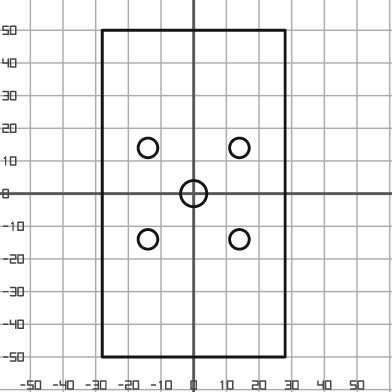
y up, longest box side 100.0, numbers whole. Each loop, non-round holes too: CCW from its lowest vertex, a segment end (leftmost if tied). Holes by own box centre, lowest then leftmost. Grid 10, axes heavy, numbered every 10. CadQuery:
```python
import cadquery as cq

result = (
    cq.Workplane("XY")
    .moveTo(-28.0, -50.0)
    .lineTo(28.0, -50.0)
    .lineTo(28.0, 50.0)
    .lineTo(-28.0, 50.0)
    .close()
    .moveTo(-14.0, -14.0)
    .circle(3.0)
    .moveTo(14.0, -14.0)
    .circle(3.0)
    .moveTo(0.0, 0.0)
    .circle(4.0)
    .moveTo(-14.0, 14.0)
    .circle(3.0)
    .moveTo(14.0, 14.0)
    .circle(3.0)
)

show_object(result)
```